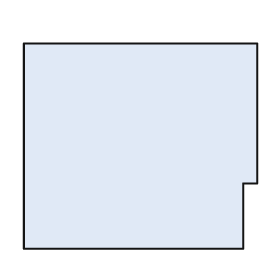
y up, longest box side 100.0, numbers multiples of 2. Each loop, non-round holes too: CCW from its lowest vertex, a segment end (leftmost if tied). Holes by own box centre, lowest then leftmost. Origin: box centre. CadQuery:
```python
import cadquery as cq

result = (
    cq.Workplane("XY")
    .moveTo(-50.0, -44.0)
    .lineTo(44.0, -44.0)
    .lineTo(44.0, -16.0)
    .lineTo(50.0, -16.0)
    .lineTo(50.0, 44.0)
    .lineTo(-50.0, 44.0)
    .close()
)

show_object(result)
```